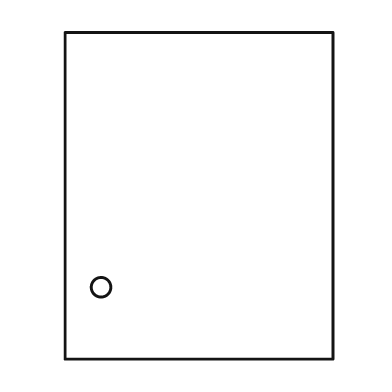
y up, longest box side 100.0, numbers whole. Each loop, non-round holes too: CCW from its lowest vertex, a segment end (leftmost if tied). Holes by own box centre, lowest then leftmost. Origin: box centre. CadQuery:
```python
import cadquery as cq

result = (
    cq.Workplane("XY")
    .moveTo(-41.0, -50.0)
    .lineTo(41.0, -50.0)
    .lineTo(41.0, 50.0)
    .lineTo(-41.0, 50.0)
    .close()
    .moveTo(-30.0, -28.0)
    .circle(3.0)
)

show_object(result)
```